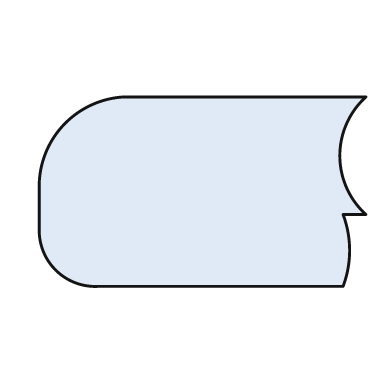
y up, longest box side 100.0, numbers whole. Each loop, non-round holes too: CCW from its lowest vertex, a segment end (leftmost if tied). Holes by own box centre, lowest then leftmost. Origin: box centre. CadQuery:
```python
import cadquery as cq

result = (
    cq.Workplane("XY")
    .moveTo(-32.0, -29.0)
    .lineTo(43.0, -29.0)
    .threePointArc((45.0, -18.0), (43.0, -7.0))
    .lineTo(50.0, -7.0)
    .threePointArc((42.0, 11.0), (50.0, 29.0))
    .lineTo(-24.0, 29.0)
    .threePointArc((-42.0, 21.0), (-50.0, 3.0))
    .lineTo(-50.0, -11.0)
    .threePointArc((-45.0, -24.0), (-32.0, -29.0))
    .close()
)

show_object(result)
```